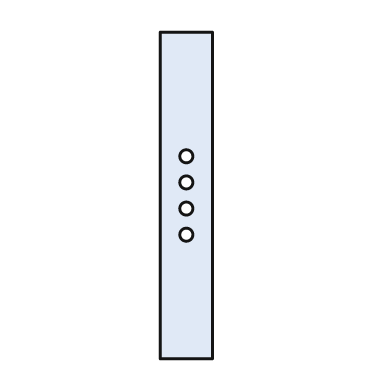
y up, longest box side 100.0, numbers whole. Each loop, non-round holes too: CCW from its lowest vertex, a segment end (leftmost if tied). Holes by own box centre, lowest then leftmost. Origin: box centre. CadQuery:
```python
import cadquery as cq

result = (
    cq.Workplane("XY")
    .moveTo(-8.0, -50.0)
    .lineTo(8.0, -50.0)
    .lineTo(8.0, 50.0)
    .lineTo(-8.0, 50.0)
    .close()
    .moveTo(0.0, -12.0)
    .circle(2.0)
    .moveTo(0.0, -4.0)
    .circle(2.0)
    .moveTo(0.0, 4.0)
    .circle(2.0)
    .moveTo(0.0, 12.0)
    .circle(2.0)
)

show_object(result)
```